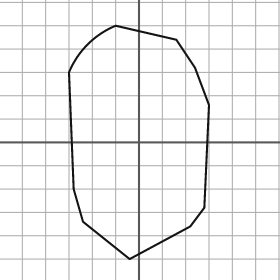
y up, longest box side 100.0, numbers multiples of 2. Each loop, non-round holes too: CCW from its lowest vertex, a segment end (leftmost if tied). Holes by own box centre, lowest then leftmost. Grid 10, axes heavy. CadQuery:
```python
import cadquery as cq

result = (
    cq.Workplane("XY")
    .moveTo(-4.0, -50.0)
    .lineTo(22.0, -36.0)
    .lineTo(28.0, -28.0)
    .lineTo(30.0, 16.0)
    .lineTo(24.0, 32.0)
    .lineTo(16.0, 44.0)
    .lineTo(-10.0, 50.0)
    .threePointArc((-22.0, 42.0), (-30.0, 30.0))
    .lineTo(-28.0, -20.0)
    .lineTo(-24.0, -34.0)
    .close()
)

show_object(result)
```